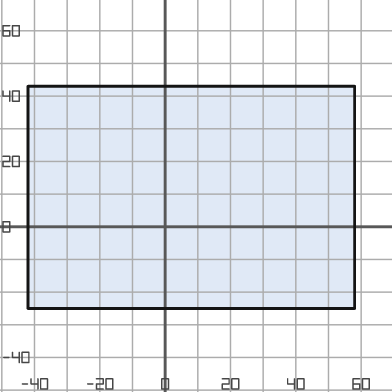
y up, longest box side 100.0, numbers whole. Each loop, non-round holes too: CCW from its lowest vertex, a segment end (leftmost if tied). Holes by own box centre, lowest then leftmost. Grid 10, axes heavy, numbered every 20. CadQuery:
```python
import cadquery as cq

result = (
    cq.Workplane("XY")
    .moveTo(-42.0, -25.0)
    .lineTo(58.0, -25.0)
    .lineTo(58.0, 43.0)
    .lineTo(-42.0, 43.0)
    .close()
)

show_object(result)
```